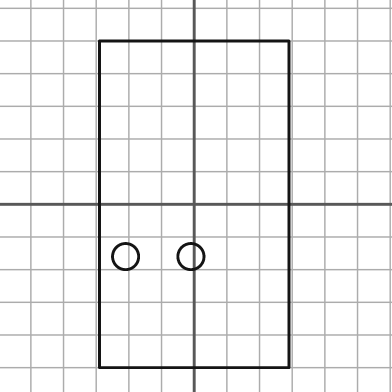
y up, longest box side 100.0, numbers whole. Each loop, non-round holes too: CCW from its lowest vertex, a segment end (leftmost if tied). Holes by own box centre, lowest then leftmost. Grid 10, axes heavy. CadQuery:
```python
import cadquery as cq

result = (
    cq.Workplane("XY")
    .moveTo(-29.0, -50.0)
    .lineTo(29.0, -50.0)
    .lineTo(29.0, 50.0)
    .lineTo(-29.0, 50.0)
    .close()
    .moveTo(-21.0, -16.0)
    .circle(4.0)
    .moveTo(-1.0, -16.0)
    .circle(4.0)
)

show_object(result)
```